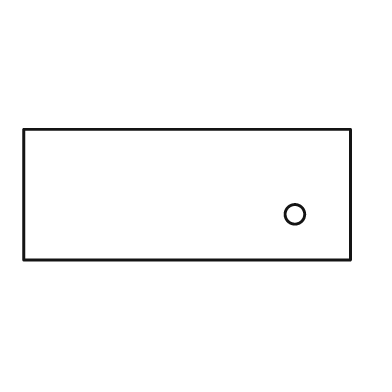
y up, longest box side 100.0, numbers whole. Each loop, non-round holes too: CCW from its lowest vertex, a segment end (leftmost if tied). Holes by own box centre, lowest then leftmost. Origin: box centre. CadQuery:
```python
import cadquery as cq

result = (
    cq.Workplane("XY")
    .moveTo(-50.0, -20.0)
    .lineTo(50.0, -20.0)
    .lineTo(50.0, 20.0)
    .lineTo(-50.0, 20.0)
    .close()
    .moveTo(33.0, -6.0)
    .circle(3.0)
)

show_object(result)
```